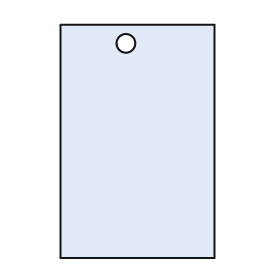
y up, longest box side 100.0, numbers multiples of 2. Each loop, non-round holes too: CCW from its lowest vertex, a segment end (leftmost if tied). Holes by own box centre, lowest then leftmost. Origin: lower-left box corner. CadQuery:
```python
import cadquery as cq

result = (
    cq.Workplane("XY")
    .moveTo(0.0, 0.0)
    .lineTo(66.0, 0.0)
    .lineTo(66.0, 100.0)
    .lineTo(0.0, 100.0)
    .close()
    .moveTo(28.0, 92.0)
    .circle(4.0)
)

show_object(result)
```